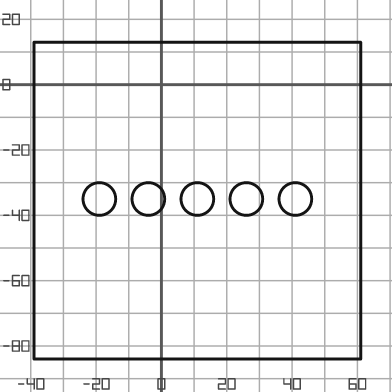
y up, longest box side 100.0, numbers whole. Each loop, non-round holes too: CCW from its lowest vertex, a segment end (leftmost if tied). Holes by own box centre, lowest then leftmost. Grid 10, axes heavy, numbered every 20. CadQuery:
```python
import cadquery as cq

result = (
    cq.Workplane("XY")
    .moveTo(-39.0, -84.0)
    .lineTo(61.0, -84.0)
    .lineTo(61.0, 13.0)
    .lineTo(-39.0, 13.0)
    .close()
    .moveTo(-19.0, -35.0)
    .circle(5.0)
    .moveTo(-4.0, -35.0)
    .circle(5.0)
    .moveTo(11.0, -35.0)
    .circle(5.0)
    .moveTo(26.0, -35.0)
    .circle(5.0)
    .moveTo(41.0, -35.0)
    .circle(5.0)
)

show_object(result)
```